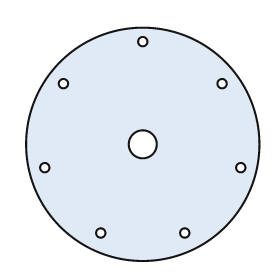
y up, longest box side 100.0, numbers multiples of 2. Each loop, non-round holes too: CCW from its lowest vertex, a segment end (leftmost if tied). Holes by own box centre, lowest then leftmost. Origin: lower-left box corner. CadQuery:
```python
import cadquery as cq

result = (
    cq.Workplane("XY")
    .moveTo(50.0, 50.0)
    .circle(50.0)
    .moveTo(32.0, 12.0)
    .circle(2.0)
    .moveTo(68.0, 12.0)
    .circle(2.0)
    .moveTo(8.0, 40.0)
    .circle(2.0)
    .moveTo(92.0, 40.0)
    .circle(2.0)
    .moveTo(50.0, 50.0)
    .circle(6.0)
    .moveTo(16.0, 76.0)
    .circle(2.0)
    .moveTo(84.0, 76.0)
    .circle(2.0)
    .moveTo(50.0, 94.0)
    .circle(2.0)
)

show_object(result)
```